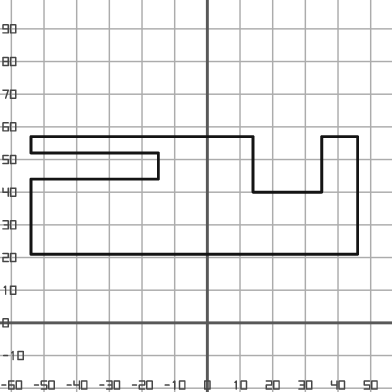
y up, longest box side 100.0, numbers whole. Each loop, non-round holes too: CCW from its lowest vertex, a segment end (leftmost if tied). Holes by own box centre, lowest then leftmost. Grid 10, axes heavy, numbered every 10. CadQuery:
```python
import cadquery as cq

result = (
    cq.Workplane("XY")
    .moveTo(-54.0, 21.0)
    .lineTo(46.0, 21.0)
    .lineTo(46.0, 57.0)
    .lineTo(35.0, 57.0)
    .lineTo(35.0, 40.0)
    .lineTo(14.0, 40.0)
    .lineTo(14.0, 57.0)
    .lineTo(-54.0, 57.0)
    .lineTo(-54.0, 52.0)
    .lineTo(-15.0, 52.0)
    .lineTo(-15.0, 44.0)
    .lineTo(-54.0, 44.0)
    .close()
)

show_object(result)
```